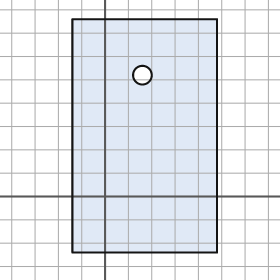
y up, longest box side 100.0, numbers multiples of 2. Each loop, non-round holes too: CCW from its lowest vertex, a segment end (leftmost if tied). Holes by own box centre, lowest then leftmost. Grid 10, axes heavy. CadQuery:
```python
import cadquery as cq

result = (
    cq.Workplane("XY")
    .moveTo(-14.0, -24.0)
    .lineTo(48.0, -24.0)
    .lineTo(48.0, 76.0)
    .lineTo(-14.0, 76.0)
    .close()
    .moveTo(16.0, 52.0)
    .circle(4.0)
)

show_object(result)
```